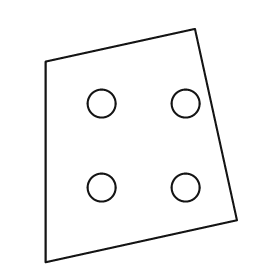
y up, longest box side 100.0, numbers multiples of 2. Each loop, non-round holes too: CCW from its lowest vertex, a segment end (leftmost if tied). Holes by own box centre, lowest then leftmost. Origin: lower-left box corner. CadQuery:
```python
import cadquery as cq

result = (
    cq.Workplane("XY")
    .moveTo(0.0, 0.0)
    .lineTo(82.0, 18.0)
    .lineTo(64.0, 100.0)
    .lineTo(0.0, 86.0)
    .close()
    .moveTo(24.0, 32.0)
    .circle(6.0)
    .moveTo(60.0, 32.0)
    .circle(6.0)
    .moveTo(24.0, 68.0)
    .circle(6.0)
    .moveTo(60.0, 68.0)
    .circle(6.0)
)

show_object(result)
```